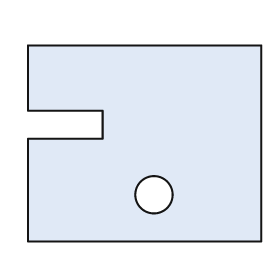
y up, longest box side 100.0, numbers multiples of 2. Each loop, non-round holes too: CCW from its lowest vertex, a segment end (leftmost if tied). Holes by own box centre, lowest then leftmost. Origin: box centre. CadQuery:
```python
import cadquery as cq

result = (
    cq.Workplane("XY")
    .moveTo(-50.0, -42.0)
    .lineTo(50.0, -42.0)
    .lineTo(50.0, 42.0)
    .lineTo(-50.0, 42.0)
    .lineTo(-50.0, 14.0)
    .lineTo(-18.0, 14.0)
    .lineTo(-18.0, 2.0)
    .lineTo(-50.0, 2.0)
    .close()
    .moveTo(4.0, -22.0)
    .circle(8.0)
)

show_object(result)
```